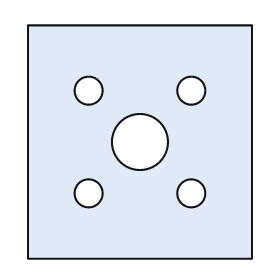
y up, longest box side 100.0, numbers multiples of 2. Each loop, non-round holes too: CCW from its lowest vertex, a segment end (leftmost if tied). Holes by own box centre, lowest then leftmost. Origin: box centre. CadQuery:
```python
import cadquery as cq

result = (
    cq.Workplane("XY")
    .moveTo(-48.0, -50.0)
    .lineTo(48.0, -50.0)
    .lineTo(48.0, 50.0)
    .lineTo(-48.0, 50.0)
    .close()
    .moveTo(-22.0, -22.0)
    .circle(6.0)
    .moveTo(22.0, -22.0)
    .circle(6.0)
    .moveTo(0.0, 0.0)
    .circle(12.0)
    .moveTo(-22.0, 22.0)
    .circle(6.0)
    .moveTo(22.0, 22.0)
    .circle(6.0)
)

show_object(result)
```